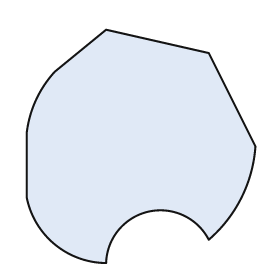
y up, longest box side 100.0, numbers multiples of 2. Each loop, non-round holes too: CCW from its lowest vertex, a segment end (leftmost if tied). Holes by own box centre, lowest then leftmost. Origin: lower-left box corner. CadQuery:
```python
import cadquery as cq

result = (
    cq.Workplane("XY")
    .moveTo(34.0, 0.0)
    .threePointArc((52.0, 22.0), (78.0, 10.0))
    .threePointArc((92.0, 28.0), (98.0, 50.0))
    .lineTo(78.0, 90.0)
    .lineTo(34.0, 100.0)
    .lineTo(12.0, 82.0)
    .threePointArc((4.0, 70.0), (0.0, 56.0))
    .lineTo(0.0, 28.0)
    .threePointArc((12.0, 8.0), (34.0, 0.0))
    .close()
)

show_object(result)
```